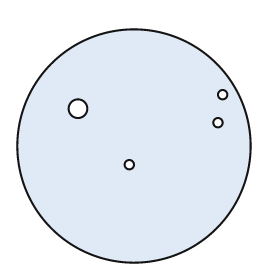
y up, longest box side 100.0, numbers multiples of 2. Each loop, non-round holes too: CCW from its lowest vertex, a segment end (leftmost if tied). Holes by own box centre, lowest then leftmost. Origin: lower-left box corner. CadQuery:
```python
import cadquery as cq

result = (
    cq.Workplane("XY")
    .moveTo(50.0, 50.0)
    .circle(50.0)
    .moveTo(48.0, 42.0)
    .circle(2.0)
    .moveTo(86.0, 60.0)
    .circle(2.0)
    .moveTo(26.0, 66.0)
    .circle(4.0)
    .moveTo(88.0, 72.0)
    .circle(2.0)
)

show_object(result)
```